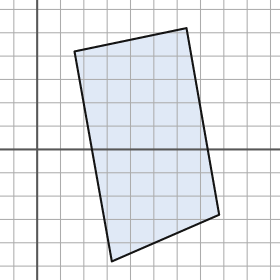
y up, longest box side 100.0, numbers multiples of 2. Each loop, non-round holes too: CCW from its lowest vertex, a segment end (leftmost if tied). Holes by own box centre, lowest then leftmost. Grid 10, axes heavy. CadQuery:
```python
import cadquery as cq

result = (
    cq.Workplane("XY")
    .moveTo(32.0, -48.0)
    .lineTo(78.0, -28.0)
    .lineTo(64.0, 52.0)
    .lineTo(16.0, 42.0)
    .close()
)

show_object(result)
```